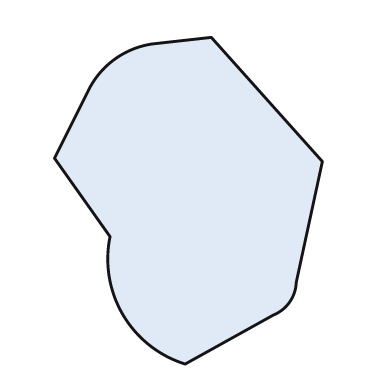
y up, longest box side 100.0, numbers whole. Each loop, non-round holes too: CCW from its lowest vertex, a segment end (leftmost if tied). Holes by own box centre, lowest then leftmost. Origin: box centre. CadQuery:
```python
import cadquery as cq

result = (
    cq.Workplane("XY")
    .moveTo(-1.0, -50.0)
    .lineTo(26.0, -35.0)
    .threePointArc((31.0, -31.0), (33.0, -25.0))
    .lineTo(41.0, 12.0)
    .lineTo(7.0, 50.0)
    .lineTo(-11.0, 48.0)
    .threePointArc((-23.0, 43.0), (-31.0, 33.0))
    .lineTo(-41.0, 13.0)
    .lineTo(-24.0, -11.0)
    .threePointArc((-20.0, -35.0), (-1.0, -50.0))
    .close()
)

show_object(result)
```